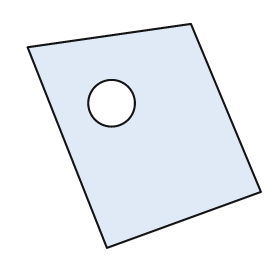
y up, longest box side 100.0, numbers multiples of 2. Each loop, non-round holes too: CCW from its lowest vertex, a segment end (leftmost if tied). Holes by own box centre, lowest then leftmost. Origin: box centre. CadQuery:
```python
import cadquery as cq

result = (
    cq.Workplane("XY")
    .moveTo(-16.0, -48.0)
    .lineTo(50.0, -24.0)
    .lineTo(20.0, 48.0)
    .lineTo(-50.0, 38.0)
    .close()
    .moveTo(-14.0, 14.0)
    .circle(10.0)
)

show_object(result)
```